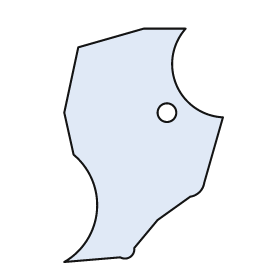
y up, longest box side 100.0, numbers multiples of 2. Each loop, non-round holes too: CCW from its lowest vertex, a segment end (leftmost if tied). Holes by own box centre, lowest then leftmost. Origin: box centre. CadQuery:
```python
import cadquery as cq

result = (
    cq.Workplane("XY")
    .moveTo(-34.0, -50.0)
    .lineTo(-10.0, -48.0)
    .threePointArc((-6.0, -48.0), (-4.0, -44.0))
    .lineTo(6.0, -32.0)
    .lineTo(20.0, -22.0)
    .threePointArc((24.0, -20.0), (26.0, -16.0))
    .lineTo(34.0, 12.0)
    .threePointArc((14.0, 26.0), (18.0, 50.0))
    .lineTo(0.0, 50.0)
    .lineTo(-28.0, 42.0)
    .lineTo(-34.0, 14.0)
    .lineTo(-30.0, -4.0)
    .threePointArc((-20.0, -28.0), (-34.0, -50.0))
    .close()
    .moveTo(10.0, 14.0)
    .circle(4.0)
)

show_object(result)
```